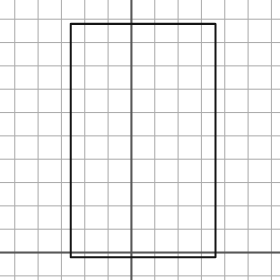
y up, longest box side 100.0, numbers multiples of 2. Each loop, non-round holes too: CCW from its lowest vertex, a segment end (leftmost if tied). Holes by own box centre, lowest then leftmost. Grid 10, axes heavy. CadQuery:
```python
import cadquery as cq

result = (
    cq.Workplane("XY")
    .moveTo(-26.0, -2.0)
    .lineTo(36.0, -2.0)
    .lineTo(36.0, 98.0)
    .lineTo(-26.0, 98.0)
    .close()
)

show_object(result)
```